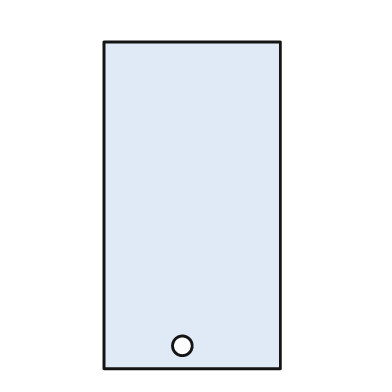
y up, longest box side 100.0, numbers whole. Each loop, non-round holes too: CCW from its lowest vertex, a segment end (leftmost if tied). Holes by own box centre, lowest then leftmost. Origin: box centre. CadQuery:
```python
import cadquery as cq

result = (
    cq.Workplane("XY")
    .moveTo(-27.0, -50.0)
    .lineTo(27.0, -50.0)
    .lineTo(27.0, 50.0)
    .lineTo(-27.0, 50.0)
    .close()
    .moveTo(-3.0, -43.0)
    .circle(3.0)
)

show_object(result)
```